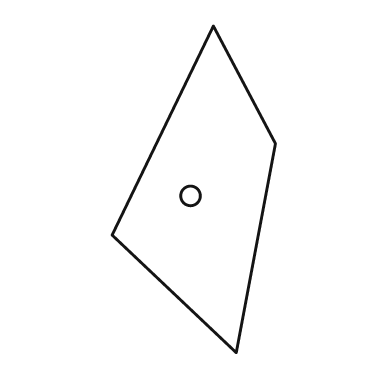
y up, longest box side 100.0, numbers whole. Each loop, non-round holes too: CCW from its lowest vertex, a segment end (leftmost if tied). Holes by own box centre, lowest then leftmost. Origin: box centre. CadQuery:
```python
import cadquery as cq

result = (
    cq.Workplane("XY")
    .moveTo(13.0, -50.0)
    .lineTo(25.0, 14.0)
    .lineTo(6.0, 50.0)
    .lineTo(-25.0, -14.0)
    .close()
    .moveTo(-1.0, -2.0)
    .circle(3.0)
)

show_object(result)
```